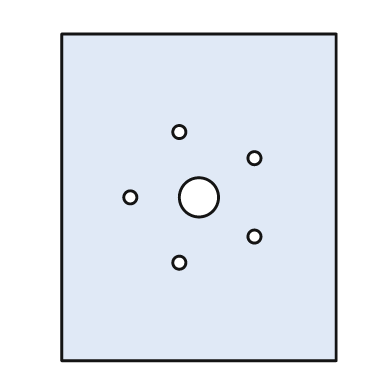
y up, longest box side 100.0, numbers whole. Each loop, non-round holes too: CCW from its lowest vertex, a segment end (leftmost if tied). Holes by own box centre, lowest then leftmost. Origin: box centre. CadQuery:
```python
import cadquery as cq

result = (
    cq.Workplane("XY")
    .moveTo(-42.0, -50.0)
    .lineTo(42.0, -50.0)
    .lineTo(42.0, 50.0)
    .lineTo(-42.0, 50.0)
    .close()
    .moveTo(-6.0, -20.0)
    .circle(2.0)
    .moveTo(17.0, -12.0)
    .circle(2.0)
    .moveTo(-21.0, 0.0)
    .circle(2.0)
    .moveTo(0.0, 0.0)
    .circle(6.0)
    .moveTo(17.0, 12.0)
    .circle(2.0)
    .moveTo(-6.0, 20.0)
    .circle(2.0)
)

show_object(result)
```